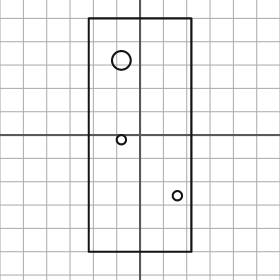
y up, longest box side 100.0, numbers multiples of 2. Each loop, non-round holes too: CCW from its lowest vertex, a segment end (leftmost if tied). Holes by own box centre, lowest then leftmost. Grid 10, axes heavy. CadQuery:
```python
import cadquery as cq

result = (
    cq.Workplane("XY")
    .moveTo(-22.0, -50.0)
    .lineTo(22.0, -50.0)
    .lineTo(22.0, 50.0)
    .lineTo(-22.0, 50.0)
    .close()
    .moveTo(16.0, -26.0)
    .circle(2.0)
    .moveTo(-8.0, -2.0)
    .circle(2.0)
    .moveTo(-8.0, 32.0)
    .circle(4.0)
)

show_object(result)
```